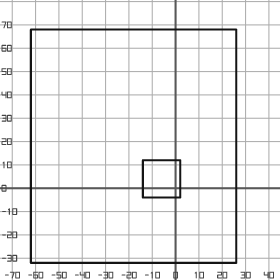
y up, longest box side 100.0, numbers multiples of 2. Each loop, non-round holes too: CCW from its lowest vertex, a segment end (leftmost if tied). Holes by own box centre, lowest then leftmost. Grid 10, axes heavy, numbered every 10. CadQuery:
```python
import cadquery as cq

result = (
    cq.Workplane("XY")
    .moveTo(-62.0, -32.0)
    .lineTo(26.0, -32.0)
    .lineTo(26.0, 68.0)
    .lineTo(-62.0, 68.0)
    .close()
    .moveTo(-14.0, -4.0)
    .lineTo(2.0, -4.0)
    .lineTo(2.0, 12.0)
    .lineTo(-14.0, 12.0)
    .close()
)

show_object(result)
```